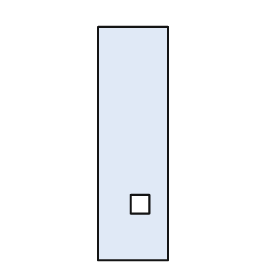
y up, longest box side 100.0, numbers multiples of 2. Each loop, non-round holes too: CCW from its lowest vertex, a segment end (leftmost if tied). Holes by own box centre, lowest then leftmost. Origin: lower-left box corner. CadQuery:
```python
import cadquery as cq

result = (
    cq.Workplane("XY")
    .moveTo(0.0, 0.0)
    .lineTo(30.0, 0.0)
    .lineTo(30.0, 100.0)
    .lineTo(0.0, 100.0)
    .close()
    .moveTo(14.0, 20.0)
    .lineTo(22.0, 20.0)
    .lineTo(22.0, 28.0)
    .lineTo(14.0, 28.0)
    .close()
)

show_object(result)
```